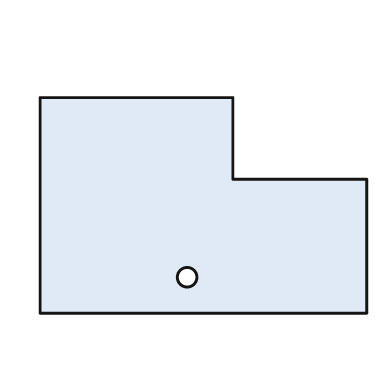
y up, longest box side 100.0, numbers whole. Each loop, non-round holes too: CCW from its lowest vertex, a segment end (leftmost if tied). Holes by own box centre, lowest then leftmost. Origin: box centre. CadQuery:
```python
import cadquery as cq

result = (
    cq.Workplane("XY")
    .moveTo(-50.0, -33.0)
    .lineTo(50.0, -33.0)
    .lineTo(50.0, 8.0)
    .lineTo(9.0, 8.0)
    .lineTo(9.0, 33.0)
    .lineTo(-50.0, 33.0)
    .close()
    .moveTo(-5.0, -22.0)
    .circle(3.0)
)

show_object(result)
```